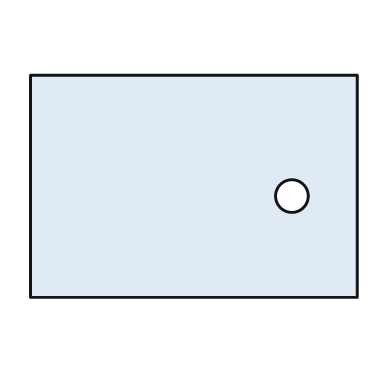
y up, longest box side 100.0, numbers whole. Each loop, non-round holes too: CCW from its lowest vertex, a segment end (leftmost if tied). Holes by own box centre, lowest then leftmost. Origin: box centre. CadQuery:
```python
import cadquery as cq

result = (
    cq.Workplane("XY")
    .moveTo(-50.0, -34.0)
    .lineTo(50.0, -34.0)
    .lineTo(50.0, 34.0)
    .lineTo(-50.0, 34.0)
    .close()
    .moveTo(30.0, -3.0)
    .circle(5.0)
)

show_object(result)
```